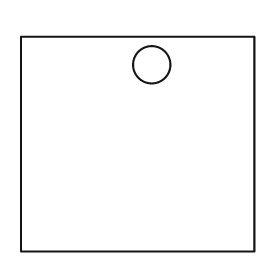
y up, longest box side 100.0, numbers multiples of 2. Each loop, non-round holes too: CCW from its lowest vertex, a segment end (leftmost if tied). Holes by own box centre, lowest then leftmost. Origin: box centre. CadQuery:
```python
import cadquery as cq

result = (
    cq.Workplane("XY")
    .moveTo(-50.0, -46.0)
    .lineTo(50.0, -46.0)
    .lineTo(50.0, 46.0)
    .lineTo(-50.0, 46.0)
    .close()
    .moveTo(6.0, 34.0)
    .circle(8.0)
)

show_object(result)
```